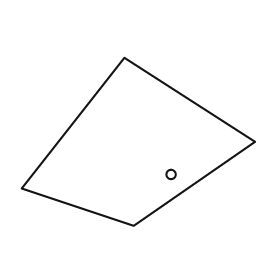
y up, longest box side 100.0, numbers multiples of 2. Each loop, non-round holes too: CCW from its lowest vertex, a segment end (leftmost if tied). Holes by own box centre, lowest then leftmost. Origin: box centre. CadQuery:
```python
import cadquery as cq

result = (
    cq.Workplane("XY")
    .moveTo(-2.0, -36.0)
    .lineTo(50.0, 0.0)
    .lineTo(-6.0, 36.0)
    .lineTo(-50.0, -20.0)
    .close()
    .moveTo(14.0, -14.0)
    .circle(2.0)
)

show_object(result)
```